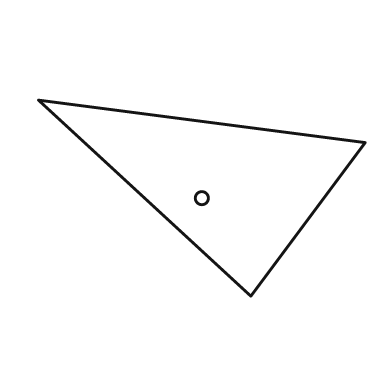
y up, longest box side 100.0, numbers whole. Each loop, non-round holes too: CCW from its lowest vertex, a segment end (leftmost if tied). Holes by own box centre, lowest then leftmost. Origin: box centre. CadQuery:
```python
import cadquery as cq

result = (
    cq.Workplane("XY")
    .moveTo(15.0, -30.0)
    .lineTo(50.0, 17.0)
    .lineTo(-50.0, 30.0)
    .close()
    .moveTo(0.0, 0.0)
    .circle(2.0)
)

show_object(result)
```